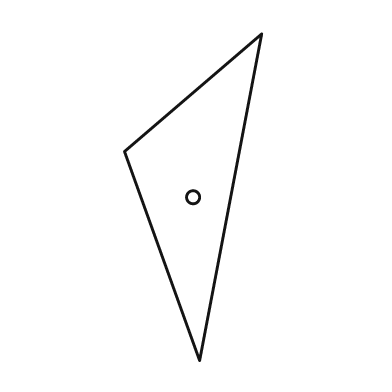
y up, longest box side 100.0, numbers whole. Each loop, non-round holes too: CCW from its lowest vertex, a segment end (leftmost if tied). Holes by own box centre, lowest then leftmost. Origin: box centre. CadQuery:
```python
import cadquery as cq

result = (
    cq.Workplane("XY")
    .moveTo(2.0, -50.0)
    .lineTo(21.0, 50.0)
    .lineTo(-21.0, 14.0)
    .close()
    .moveTo(0.0, 0.0)
    .circle(2.0)
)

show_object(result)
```